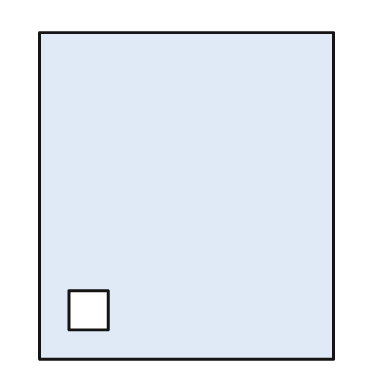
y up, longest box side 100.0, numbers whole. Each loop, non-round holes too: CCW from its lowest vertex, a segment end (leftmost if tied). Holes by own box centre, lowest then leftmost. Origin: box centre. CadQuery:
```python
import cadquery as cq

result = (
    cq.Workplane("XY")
    .moveTo(-45.0, -50.0)
    .lineTo(45.0, -50.0)
    .lineTo(45.0, 50.0)
    .lineTo(-45.0, 50.0)
    .close()
    .moveTo(-36.0, -41.0)
    .lineTo(-24.0, -41.0)
    .lineTo(-24.0, -29.0)
    .lineTo(-36.0, -29.0)
    .close()
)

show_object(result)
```